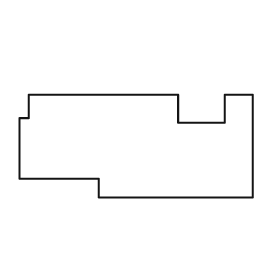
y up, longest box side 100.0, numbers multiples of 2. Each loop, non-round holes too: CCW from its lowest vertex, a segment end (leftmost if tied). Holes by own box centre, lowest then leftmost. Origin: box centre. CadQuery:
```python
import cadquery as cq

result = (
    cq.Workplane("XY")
    .moveTo(-16.0, -22.0)
    .lineTo(50.0, -22.0)
    .lineTo(50.0, 22.0)
    .lineTo(38.0, 22.0)
    .lineTo(38.0, 10.0)
    .lineTo(18.0, 10.0)
    .lineTo(18.0, 22.0)
    .lineTo(-46.0, 22.0)
    .lineTo(-46.0, 12.0)
    .lineTo(-50.0, 12.0)
    .lineTo(-50.0, -14.0)
    .lineTo(-16.0, -14.0)
    .close()
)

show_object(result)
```